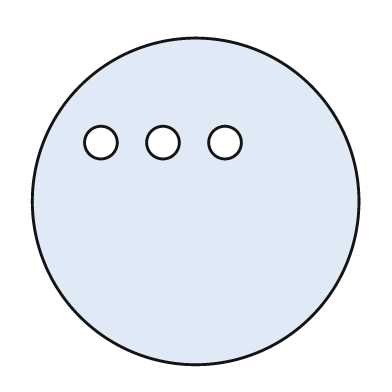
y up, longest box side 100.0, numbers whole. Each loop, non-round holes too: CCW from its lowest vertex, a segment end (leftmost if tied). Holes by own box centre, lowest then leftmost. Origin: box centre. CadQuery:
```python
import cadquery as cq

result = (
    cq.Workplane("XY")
    .moveTo(0.0, 0.0)
    .circle(50.0)
    .moveTo(-29.0, 18.0)
    .circle(5.0)
    .moveTo(-10.0, 18.0)
    .circle(5.0)
    .moveTo(9.0, 18.0)
    .circle(5.0)
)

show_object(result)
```